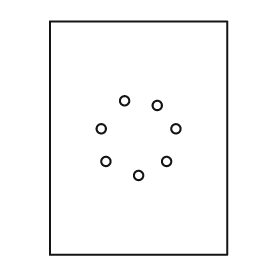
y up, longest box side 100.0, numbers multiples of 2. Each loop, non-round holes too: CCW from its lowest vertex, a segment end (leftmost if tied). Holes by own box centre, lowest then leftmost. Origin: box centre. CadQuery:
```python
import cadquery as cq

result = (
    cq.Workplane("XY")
    .moveTo(-38.0, -50.0)
    .lineTo(38.0, -50.0)
    .lineTo(38.0, 50.0)
    .lineTo(-38.0, 50.0)
    .close()
    .moveTo(0.0, -16.0)
    .circle(2.0)
    .moveTo(-14.0, -10.0)
    .circle(2.0)
    .moveTo(12.0, -10.0)
    .circle(2.0)
    .moveTo(-16.0, 4.0)
    .circle(2.0)
    .moveTo(16.0, 4.0)
    .circle(2.0)
    .moveTo(8.0, 14.0)
    .circle(2.0)
    .moveTo(-6.0, 16.0)
    .circle(2.0)
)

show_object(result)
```